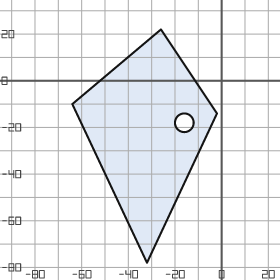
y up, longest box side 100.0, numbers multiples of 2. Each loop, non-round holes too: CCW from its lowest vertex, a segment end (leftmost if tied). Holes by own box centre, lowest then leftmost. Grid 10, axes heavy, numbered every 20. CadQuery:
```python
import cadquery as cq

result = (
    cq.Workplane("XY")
    .moveTo(-32.0, -78.0)
    .lineTo(-2.0, -14.0)
    .lineTo(-26.0, 22.0)
    .lineTo(-64.0, -10.0)
    .close()
    .moveTo(-16.0, -18.0)
    .circle(4.0)
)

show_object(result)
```